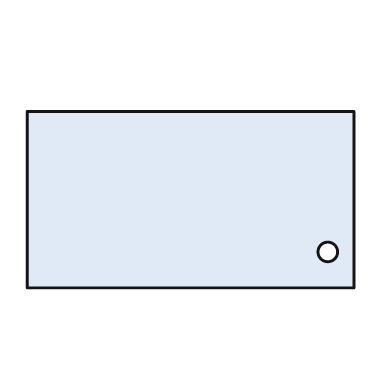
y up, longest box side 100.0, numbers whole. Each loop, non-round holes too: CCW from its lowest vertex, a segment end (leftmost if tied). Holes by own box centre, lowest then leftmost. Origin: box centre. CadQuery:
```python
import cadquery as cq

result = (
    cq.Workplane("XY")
    .moveTo(-50.0, -27.0)
    .lineTo(50.0, -27.0)
    .lineTo(50.0, 27.0)
    .lineTo(-50.0, 27.0)
    .close()
    .moveTo(42.0, -16.0)
    .circle(3.0)
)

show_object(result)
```